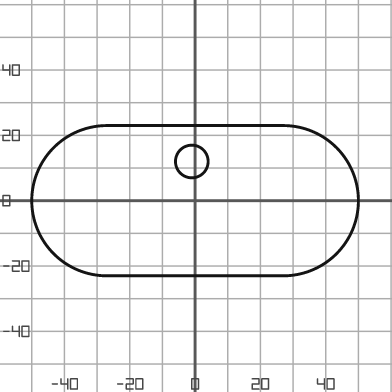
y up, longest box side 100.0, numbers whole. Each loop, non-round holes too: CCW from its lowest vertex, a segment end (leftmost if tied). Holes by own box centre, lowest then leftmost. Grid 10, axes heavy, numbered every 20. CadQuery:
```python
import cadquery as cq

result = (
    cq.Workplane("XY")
    .moveTo(-27.0, -23.0)
    .lineTo(27.0, -23.0)
    .threePointArc((50.0, 0.0), (27.0, 23.0))
    .lineTo(-27.0, 23.0)
    .threePointArc((-50.0, 0.0), (-27.0, -23.0))
    .close()
    .moveTo(-1.0, 12.0)
    .circle(5.0)
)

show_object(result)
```